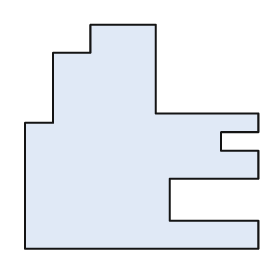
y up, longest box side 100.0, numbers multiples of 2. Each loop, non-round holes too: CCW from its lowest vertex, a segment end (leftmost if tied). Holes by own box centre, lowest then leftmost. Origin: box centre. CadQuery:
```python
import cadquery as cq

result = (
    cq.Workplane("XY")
    .moveTo(-50.0, -48.0)
    .lineTo(50.0, -48.0)
    .lineTo(50.0, -36.0)
    .lineTo(12.0, -36.0)
    .lineTo(12.0, -18.0)
    .lineTo(50.0, -18.0)
    .lineTo(50.0, -6.0)
    .lineTo(34.0, -6.0)
    .lineTo(34.0, 2.0)
    .lineTo(50.0, 2.0)
    .lineTo(50.0, 10.0)
    .lineTo(6.0, 10.0)
    .lineTo(6.0, 48.0)
    .lineTo(-22.0, 48.0)
    .lineTo(-22.0, 36.0)
    .lineTo(-38.0, 36.0)
    .lineTo(-38.0, 6.0)
    .lineTo(-50.0, 6.0)
    .close()
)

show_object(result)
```